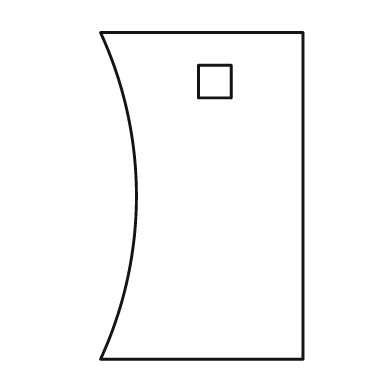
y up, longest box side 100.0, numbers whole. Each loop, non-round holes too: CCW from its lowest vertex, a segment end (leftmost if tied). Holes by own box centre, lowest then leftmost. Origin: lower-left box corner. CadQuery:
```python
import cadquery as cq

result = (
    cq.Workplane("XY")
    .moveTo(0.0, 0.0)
    .lineTo(62.0, 0.0)
    .lineTo(62.0, 100.0)
    .lineTo(0.0, 100.0)
    .threePointArc((11.0, 50.0), (0.0, 0.0))
    .close()
    .moveTo(30.0, 80.0)
    .lineTo(40.0, 80.0)
    .lineTo(40.0, 90.0)
    .lineTo(30.0, 90.0)
    .close()
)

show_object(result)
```